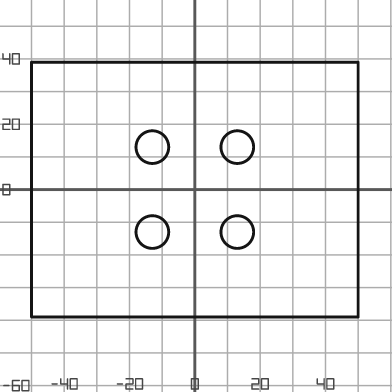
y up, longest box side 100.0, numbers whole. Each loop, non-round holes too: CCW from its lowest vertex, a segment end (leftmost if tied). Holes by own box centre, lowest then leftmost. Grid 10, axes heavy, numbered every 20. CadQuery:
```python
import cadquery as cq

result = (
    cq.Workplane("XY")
    .moveTo(-50.0, -39.0)
    .lineTo(50.0, -39.0)
    .lineTo(50.0, 39.0)
    .lineTo(-50.0, 39.0)
    .close()
    .moveTo(-13.0, -13.0)
    .circle(5.0)
    .moveTo(13.0, -13.0)
    .circle(5.0)
    .moveTo(-13.0, 13.0)
    .circle(5.0)
    .moveTo(13.0, 13.0)
    .circle(5.0)
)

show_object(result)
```